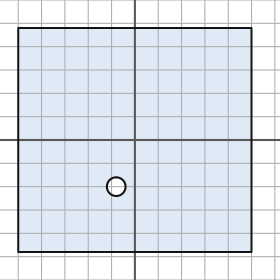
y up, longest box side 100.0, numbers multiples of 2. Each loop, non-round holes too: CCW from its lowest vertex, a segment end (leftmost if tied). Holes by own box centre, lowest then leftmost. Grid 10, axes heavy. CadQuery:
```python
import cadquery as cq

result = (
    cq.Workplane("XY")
    .moveTo(-50.0, -48.0)
    .lineTo(50.0, -48.0)
    .lineTo(50.0, 48.0)
    .lineTo(-50.0, 48.0)
    .close()
    .moveTo(-8.0, -20.0)
    .circle(4.0)
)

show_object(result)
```